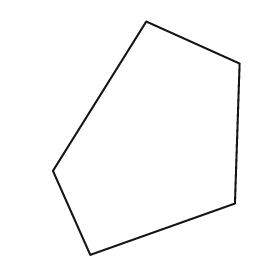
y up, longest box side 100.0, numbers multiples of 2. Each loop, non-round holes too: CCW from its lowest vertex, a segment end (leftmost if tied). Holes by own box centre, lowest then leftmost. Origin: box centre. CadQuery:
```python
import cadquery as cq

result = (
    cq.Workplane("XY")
    .moveTo(-24.0, -50.0)
    .lineTo(38.0, -28.0)
    .lineTo(40.0, 32.0)
    .lineTo(0.0, 50.0)
    .lineTo(-40.0, -14.0)
    .close()
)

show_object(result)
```